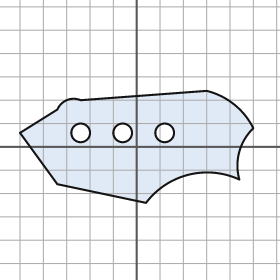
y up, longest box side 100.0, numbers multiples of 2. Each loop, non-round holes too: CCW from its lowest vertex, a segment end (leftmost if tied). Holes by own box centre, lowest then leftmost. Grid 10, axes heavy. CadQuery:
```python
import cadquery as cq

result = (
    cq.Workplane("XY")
    .moveTo(4.0, -24.0)
    .threePointArc((22.0, -12.0), (44.0, -14.0))
    .threePointArc((44.0, -2.0), (50.0, 8.0))
    .threePointArc((42.0, 18.0), (30.0, 24.0))
    .lineTo(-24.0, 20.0)
    .threePointArc((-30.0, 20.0), (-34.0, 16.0))
    .lineTo(-50.0, 6.0)
    .lineTo(-34.0, -16.0)
    .close()
    .moveTo(-24.0, 6.0)
    .circle(4.0)
    .moveTo(-6.0, 6.0)
    .circle(4.0)
    .moveTo(12.0, 6.0)
    .circle(4.0)
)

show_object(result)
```